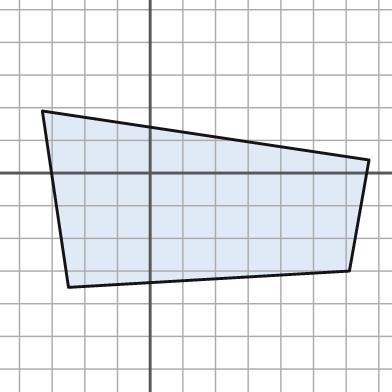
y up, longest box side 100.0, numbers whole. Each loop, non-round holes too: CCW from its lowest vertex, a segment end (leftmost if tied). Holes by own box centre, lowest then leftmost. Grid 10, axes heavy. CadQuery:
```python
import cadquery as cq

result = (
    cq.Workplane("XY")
    .moveTo(-25.0, -35.0)
    .lineTo(61.0, -30.0)
    .lineTo(67.0, 4.0)
    .lineTo(-33.0, 19.0)
    .close()
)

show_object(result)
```